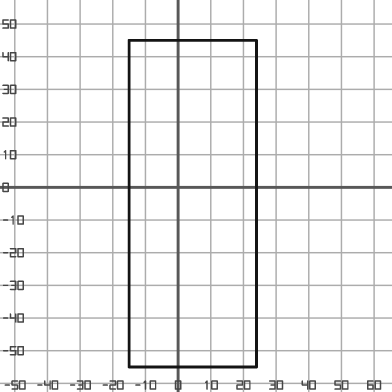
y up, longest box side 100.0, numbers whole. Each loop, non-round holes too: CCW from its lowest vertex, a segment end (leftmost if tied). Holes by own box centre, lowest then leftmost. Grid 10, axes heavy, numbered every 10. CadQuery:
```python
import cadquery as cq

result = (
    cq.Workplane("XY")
    .moveTo(-15.0, -55.0)
    .lineTo(24.0, -55.0)
    .lineTo(24.0, 45.0)
    .lineTo(-15.0, 45.0)
    .close()
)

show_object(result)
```